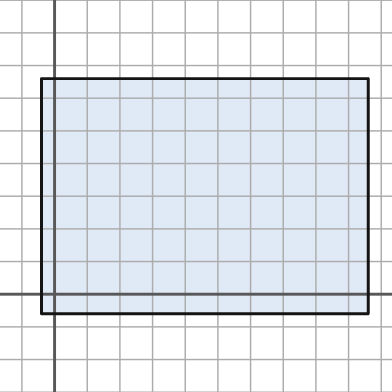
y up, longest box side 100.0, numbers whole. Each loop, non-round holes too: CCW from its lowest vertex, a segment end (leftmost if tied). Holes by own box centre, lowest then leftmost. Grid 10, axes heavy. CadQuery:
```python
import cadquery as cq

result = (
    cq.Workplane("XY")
    .moveTo(-4.0, -6.0)
    .lineTo(96.0, -6.0)
    .lineTo(96.0, 66.0)
    .lineTo(-4.0, 66.0)
    .close()
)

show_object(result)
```